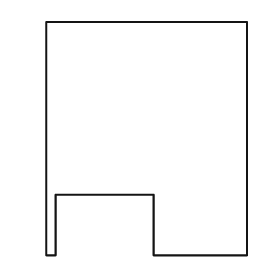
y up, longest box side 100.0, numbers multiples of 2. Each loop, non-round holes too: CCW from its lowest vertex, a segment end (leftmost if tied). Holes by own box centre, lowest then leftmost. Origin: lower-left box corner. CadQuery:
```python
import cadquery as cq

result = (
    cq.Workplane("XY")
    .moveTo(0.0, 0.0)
    .lineTo(4.0, 0.0)
    .lineTo(4.0, 26.0)
    .lineTo(46.0, 26.0)
    .lineTo(46.0, 0.0)
    .lineTo(86.0, 0.0)
    .lineTo(86.0, 100.0)
    .lineTo(0.0, 100.0)
    .close()
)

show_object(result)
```